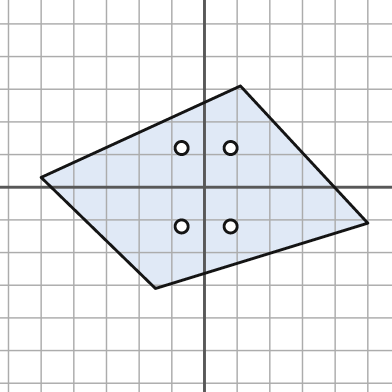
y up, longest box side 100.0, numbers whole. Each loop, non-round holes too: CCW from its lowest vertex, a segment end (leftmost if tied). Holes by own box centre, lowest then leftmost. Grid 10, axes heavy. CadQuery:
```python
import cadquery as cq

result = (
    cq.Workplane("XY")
    .moveTo(-15.0, -31.0)
    .lineTo(50.0, -11.0)
    .lineTo(11.0, 31.0)
    .lineTo(-50.0, 3.0)
    .close()
    .moveTo(-7.0, -12.0)
    .circle(2.0)
    .moveTo(8.0, -12.0)
    .circle(2.0)
    .moveTo(-7.0, 12.0)
    .circle(2.0)
    .moveTo(8.0, 12.0)
    .circle(2.0)
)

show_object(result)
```